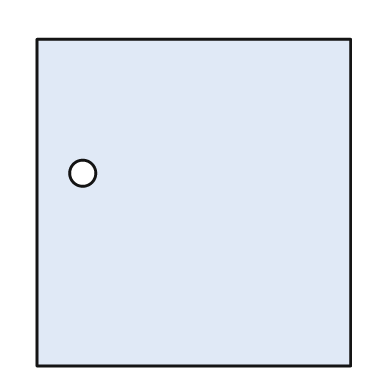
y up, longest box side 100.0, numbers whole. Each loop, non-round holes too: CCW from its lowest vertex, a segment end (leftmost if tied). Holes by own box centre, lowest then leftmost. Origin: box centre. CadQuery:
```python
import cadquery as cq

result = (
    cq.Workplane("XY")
    .moveTo(-48.0, -50.0)
    .lineTo(48.0, -50.0)
    .lineTo(48.0, 50.0)
    .lineTo(-48.0, 50.0)
    .close()
    .moveTo(-34.0, 9.0)
    .circle(4.0)
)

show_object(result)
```